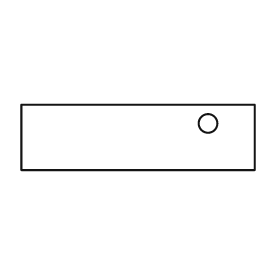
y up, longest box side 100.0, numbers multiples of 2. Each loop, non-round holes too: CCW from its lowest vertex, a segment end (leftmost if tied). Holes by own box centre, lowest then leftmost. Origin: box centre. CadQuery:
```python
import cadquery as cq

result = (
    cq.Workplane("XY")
    .moveTo(-50.0, -14.0)
    .lineTo(50.0, -14.0)
    .lineTo(50.0, 14.0)
    .lineTo(-50.0, 14.0)
    .close()
    .moveTo(30.0, 6.0)
    .circle(4.0)
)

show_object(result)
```